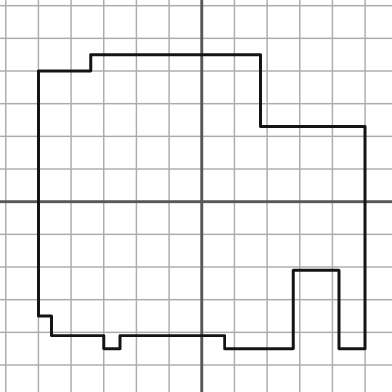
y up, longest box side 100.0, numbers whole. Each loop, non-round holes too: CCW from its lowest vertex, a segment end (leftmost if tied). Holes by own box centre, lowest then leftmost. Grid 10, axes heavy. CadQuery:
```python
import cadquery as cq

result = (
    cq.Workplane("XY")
    .moveTo(-30.0, -45.0)
    .lineTo(-25.0, -45.0)
    .lineTo(-25.0, -41.0)
    .lineTo(7.0, -41.0)
    .lineTo(7.0, -45.0)
    .lineTo(28.0, -45.0)
    .lineTo(28.0, -21.0)
    .lineTo(42.0, -21.0)
    .lineTo(42.0, -45.0)
    .lineTo(50.0, -45.0)
    .lineTo(50.0, 23.0)
    .lineTo(18.0, 23.0)
    .lineTo(18.0, 45.0)
    .lineTo(-34.0, 45.0)
    .lineTo(-34.0, 40.0)
    .lineTo(-50.0, 40.0)
    .lineTo(-50.0, -35.0)
    .lineTo(-46.0, -35.0)
    .lineTo(-46.0, -41.0)
    .lineTo(-30.0, -41.0)
    .close()
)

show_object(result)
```